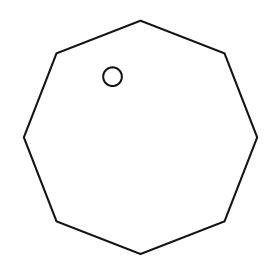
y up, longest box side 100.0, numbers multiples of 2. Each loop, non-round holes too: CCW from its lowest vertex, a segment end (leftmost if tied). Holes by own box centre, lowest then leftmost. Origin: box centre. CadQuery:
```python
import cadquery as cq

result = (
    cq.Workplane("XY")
    .moveTo(0.0, -50.0)
    .lineTo(36.0, -36.0)
    .lineTo(50.0, 0.0)
    .lineTo(36.0, 36.0)
    .lineTo(0.0, 50.0)
    .lineTo(-36.0, 36.0)
    .lineTo(-50.0, 0.0)
    .lineTo(-36.0, -36.0)
    .close()
    .moveTo(-12.0, 26.0)
    .circle(4.0)
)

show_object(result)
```